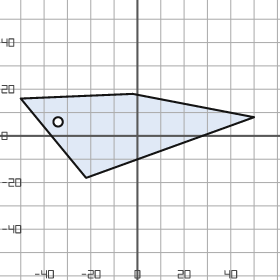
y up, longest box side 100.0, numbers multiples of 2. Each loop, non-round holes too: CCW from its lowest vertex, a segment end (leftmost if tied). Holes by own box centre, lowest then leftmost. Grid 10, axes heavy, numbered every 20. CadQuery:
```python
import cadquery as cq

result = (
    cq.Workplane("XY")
    .moveTo(-22.0, -18.0)
    .lineTo(50.0, 8.0)
    .lineTo(-2.0, 18.0)
    .lineTo(-50.0, 16.0)
    .close()
    .moveTo(-34.0, 6.0)
    .circle(2.0)
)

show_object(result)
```